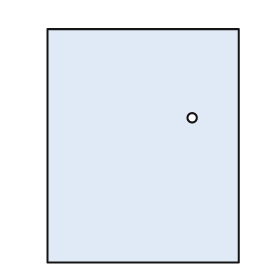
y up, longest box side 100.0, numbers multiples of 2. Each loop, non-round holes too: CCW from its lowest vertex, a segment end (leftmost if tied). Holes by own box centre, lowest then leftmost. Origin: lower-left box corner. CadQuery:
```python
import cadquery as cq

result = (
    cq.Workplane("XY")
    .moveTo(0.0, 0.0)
    .lineTo(82.0, 0.0)
    .lineTo(82.0, 100.0)
    .lineTo(0.0, 100.0)
    .close()
    .moveTo(62.0, 62.0)
    .circle(2.0)
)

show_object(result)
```